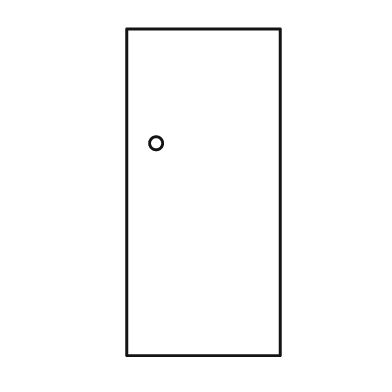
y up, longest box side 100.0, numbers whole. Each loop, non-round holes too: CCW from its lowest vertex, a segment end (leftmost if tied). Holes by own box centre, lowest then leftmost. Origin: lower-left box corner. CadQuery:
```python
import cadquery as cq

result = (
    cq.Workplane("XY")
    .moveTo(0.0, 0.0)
    .lineTo(47.0, 0.0)
    .lineTo(47.0, 100.0)
    .lineTo(0.0, 100.0)
    .close()
    .moveTo(9.0, 65.0)
    .circle(2.0)
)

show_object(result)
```